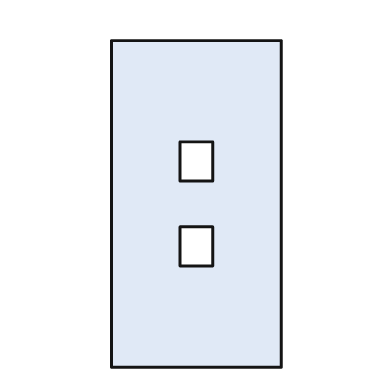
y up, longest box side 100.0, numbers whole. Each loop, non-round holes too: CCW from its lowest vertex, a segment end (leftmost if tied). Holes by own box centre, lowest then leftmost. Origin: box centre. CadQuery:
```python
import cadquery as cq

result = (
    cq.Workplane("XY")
    .moveTo(-26.0, -50.0)
    .lineTo(26.0, -50.0)
    .lineTo(26.0, 50.0)
    .lineTo(-26.0, 50.0)
    .close()
    .moveTo(-5.0, -19.0)
    .lineTo(5.0, -19.0)
    .lineTo(5.0, -7.0)
    .lineTo(-5.0, -7.0)
    .close()
    .moveTo(-5.0, 7.0)
    .lineTo(5.0, 7.0)
    .lineTo(5.0, 19.0)
    .lineTo(-5.0, 19.0)
    .close()
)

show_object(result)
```